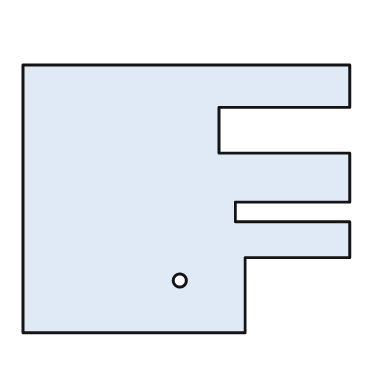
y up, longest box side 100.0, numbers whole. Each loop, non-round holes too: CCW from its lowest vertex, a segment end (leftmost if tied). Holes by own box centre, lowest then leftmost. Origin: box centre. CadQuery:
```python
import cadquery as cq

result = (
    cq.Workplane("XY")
    .moveTo(-50.0, -41.0)
    .lineTo(18.0, -41.0)
    .lineTo(18.0, -18.0)
    .lineTo(50.0, -18.0)
    .lineTo(50.0, -7.0)
    .lineTo(15.0, -7.0)
    .lineTo(15.0, -1.0)
    .lineTo(50.0, -1.0)
    .lineTo(50.0, 14.0)
    .lineTo(10.0, 14.0)
    .lineTo(10.0, 28.0)
    .lineTo(50.0, 28.0)
    .lineTo(50.0, 41.0)
    .lineTo(-50.0, 41.0)
    .close()
    .moveTo(-2.0, -25.0)
    .circle(2.0)
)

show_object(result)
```